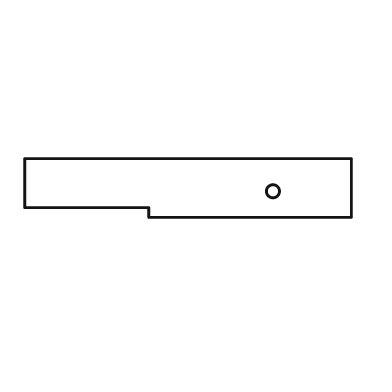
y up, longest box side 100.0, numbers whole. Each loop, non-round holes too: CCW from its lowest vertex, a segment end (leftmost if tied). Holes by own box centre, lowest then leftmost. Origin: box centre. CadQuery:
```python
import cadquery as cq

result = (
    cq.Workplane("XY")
    .moveTo(-12.0, -9.0)
    .lineTo(50.0, -9.0)
    .lineTo(50.0, 9.0)
    .lineTo(-50.0, 9.0)
    .lineTo(-50.0, -6.0)
    .lineTo(-12.0, -6.0)
    .close()
    .moveTo(26.0, -1.0)
    .circle(2.0)
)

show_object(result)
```